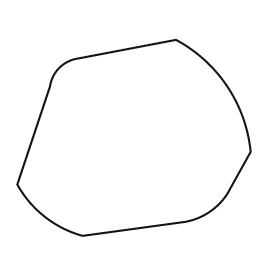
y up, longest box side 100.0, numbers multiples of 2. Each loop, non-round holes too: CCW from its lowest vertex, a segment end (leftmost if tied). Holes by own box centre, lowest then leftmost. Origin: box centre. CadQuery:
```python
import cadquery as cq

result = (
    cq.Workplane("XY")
    .moveTo(-22.0, -42.0)
    .lineTo(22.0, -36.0)
    .threePointArc((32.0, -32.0), (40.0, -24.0))
    .lineTo(50.0, -6.0)
    .threePointArc((40.0, 22.0), (18.0, 42.0))
    .lineTo(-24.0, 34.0)
    .threePointArc((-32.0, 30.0), (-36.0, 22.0))
    .lineTo(-50.0, -20.0)
    .threePointArc((-38.0, -34.0), (-22.0, -42.0))
    .close()
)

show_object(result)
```